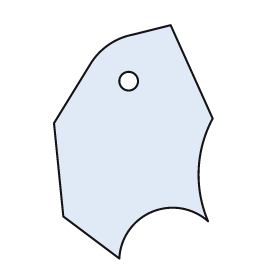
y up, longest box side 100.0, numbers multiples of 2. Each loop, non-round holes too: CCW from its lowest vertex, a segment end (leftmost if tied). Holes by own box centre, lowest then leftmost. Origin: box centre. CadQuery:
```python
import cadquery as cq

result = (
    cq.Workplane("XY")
    .moveTo(-6.0, -50.0)
    .threePointArc((8.0, -30.0), (32.0, -34.0))
    .threePointArc((28.0, -12.0), (34.0, 10.0))
    .lineTo(16.0, 50.0)
    .lineTo(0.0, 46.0)
    .threePointArc((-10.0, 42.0), (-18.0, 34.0))
    .lineTo(-34.0, 8.0)
    .lineTo(-30.0, -32.0)
    .close()
    .moveTo(-2.0, 26.0)
    .circle(4.0)
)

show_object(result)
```